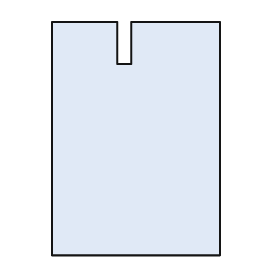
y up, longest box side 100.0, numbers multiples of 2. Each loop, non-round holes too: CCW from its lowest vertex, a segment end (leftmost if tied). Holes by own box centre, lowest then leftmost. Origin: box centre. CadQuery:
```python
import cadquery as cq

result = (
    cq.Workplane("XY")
    .moveTo(-36.0, -50.0)
    .lineTo(36.0, -50.0)
    .lineTo(36.0, 50.0)
    .lineTo(-2.0, 50.0)
    .lineTo(-2.0, 32.0)
    .lineTo(-8.0, 32.0)
    .lineTo(-8.0, 50.0)
    .lineTo(-36.0, 50.0)
    .close()
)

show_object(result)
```